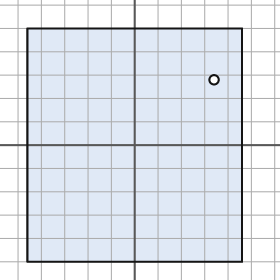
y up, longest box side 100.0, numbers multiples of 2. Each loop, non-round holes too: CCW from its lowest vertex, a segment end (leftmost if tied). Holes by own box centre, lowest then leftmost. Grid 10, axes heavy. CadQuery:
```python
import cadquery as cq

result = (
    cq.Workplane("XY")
    .moveTo(-46.0, -50.0)
    .lineTo(46.0, -50.0)
    .lineTo(46.0, 50.0)
    .lineTo(-46.0, 50.0)
    .close()
    .moveTo(34.0, 28.0)
    .circle(2.0)
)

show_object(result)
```